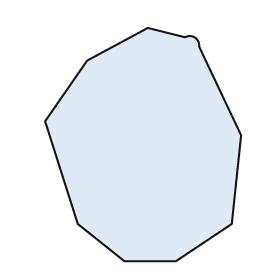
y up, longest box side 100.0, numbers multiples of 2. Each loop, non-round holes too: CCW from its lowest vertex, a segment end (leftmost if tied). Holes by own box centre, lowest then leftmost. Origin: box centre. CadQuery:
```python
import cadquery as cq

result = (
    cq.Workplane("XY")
    .moveTo(-8.0, -50.0)
    .lineTo(14.0, -50.0)
    .lineTo(38.0, -34.0)
    .lineTo(42.0, 4.0)
    .lineTo(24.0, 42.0)
    .threePointArc((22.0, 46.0), (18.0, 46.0))
    .lineTo(2.0, 50.0)
    .lineTo(-24.0, 36.0)
    .lineTo(-42.0, 10.0)
    .lineTo(-28.0, -34.0)
    .close()
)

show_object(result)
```